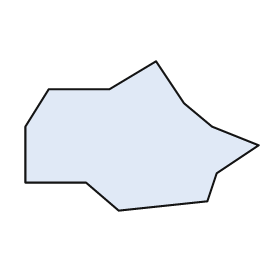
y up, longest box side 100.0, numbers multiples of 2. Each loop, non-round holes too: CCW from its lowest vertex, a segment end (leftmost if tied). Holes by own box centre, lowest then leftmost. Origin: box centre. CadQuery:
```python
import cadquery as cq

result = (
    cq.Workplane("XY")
    .moveTo(-10.0, -32.0)
    .lineTo(28.0, -28.0)
    .lineTo(32.0, -16.0)
    .lineTo(50.0, -4.0)
    .lineTo(30.0, 4.0)
    .lineTo(18.0, 14.0)
    .lineTo(6.0, 32.0)
    .lineTo(-14.0, 20.0)
    .lineTo(-40.0, 20.0)
    .lineTo(-50.0, 4.0)
    .lineTo(-50.0, -20.0)
    .lineTo(-24.0, -20.0)
    .close()
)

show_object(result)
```